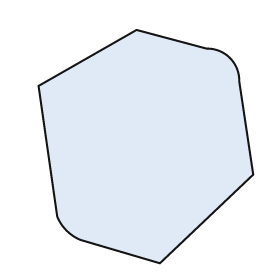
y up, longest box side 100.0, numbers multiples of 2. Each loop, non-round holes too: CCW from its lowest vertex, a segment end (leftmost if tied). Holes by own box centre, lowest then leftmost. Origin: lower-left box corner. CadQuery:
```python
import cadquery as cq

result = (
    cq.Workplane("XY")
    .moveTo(52.0, 0.0)
    .lineTo(92.0, 38.0)
    .lineTo(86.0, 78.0)
    .threePointArc((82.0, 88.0), (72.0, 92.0))
    .lineTo(42.0, 100.0)
    .lineTo(0.0, 76.0)
    .lineTo(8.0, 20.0)
    .threePointArc((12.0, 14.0), (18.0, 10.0))
    .close()
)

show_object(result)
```